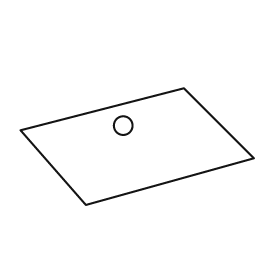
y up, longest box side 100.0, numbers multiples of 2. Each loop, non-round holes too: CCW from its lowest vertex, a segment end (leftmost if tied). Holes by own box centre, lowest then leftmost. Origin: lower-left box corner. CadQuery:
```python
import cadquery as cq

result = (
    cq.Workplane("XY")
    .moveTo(28.0, 0.0)
    .lineTo(100.0, 20.0)
    .lineTo(70.0, 50.0)
    .lineTo(0.0, 32.0)
    .close()
    .moveTo(44.0, 34.0)
    .circle(4.0)
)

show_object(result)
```